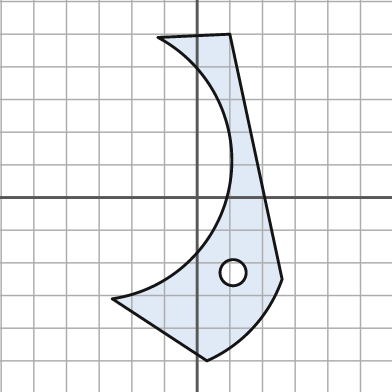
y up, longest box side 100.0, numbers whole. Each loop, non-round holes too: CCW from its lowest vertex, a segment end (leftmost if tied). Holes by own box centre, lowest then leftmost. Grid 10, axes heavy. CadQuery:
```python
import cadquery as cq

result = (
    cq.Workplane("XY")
    .moveTo(3.0, -50.0)
    .threePointArc((17.0, -40.0), (26.0, -25.0))
    .lineTo(10.0, 50.0)
    .lineTo(-12.0, 49.0)
    .threePointArc((10.0, 4.0), (-26.0, -31.0))
    .close()
    .moveTo(11.0, -23.0)
    .circle(4.0)
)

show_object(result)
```